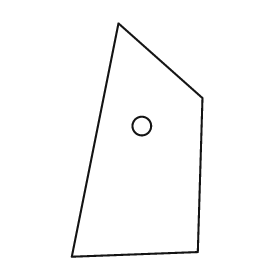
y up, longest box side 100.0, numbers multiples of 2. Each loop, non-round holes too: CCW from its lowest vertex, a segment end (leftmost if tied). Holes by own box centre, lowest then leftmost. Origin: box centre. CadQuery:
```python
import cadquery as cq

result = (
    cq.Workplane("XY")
    .moveTo(-28.0, -50.0)
    .lineTo(26.0, -48.0)
    .lineTo(28.0, 18.0)
    .lineTo(-8.0, 50.0)
    .close()
    .moveTo(2.0, 6.0)
    .circle(4.0)
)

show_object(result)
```